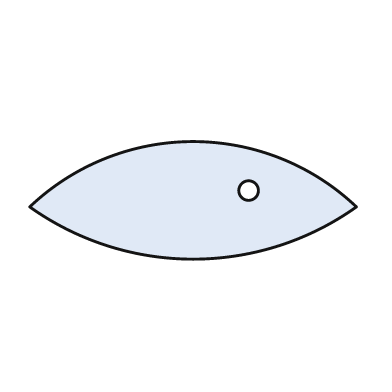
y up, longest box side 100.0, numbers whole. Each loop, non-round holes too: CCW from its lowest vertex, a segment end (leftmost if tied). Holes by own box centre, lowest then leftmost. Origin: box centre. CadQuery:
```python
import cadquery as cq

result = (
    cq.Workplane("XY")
    .moveTo(-50.0, -2.0)
    .threePointArc((0.0, -18.0), (50.0, -2.0))
    .threePointArc((0.0, 18.0), (-50.0, -2.0))
    .close()
    .moveTo(17.0, 3.0)
    .circle(3.0)
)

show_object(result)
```